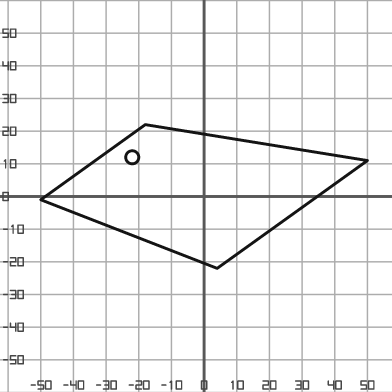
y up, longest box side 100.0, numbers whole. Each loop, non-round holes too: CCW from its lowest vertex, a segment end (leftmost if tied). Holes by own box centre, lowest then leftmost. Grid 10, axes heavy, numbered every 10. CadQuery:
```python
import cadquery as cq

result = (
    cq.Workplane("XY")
    .moveTo(4.0, -22.0)
    .lineTo(50.0, 11.0)
    .lineTo(-18.0, 22.0)
    .lineTo(-50.0, -1.0)
    .close()
    .moveTo(-22.0, 12.0)
    .circle(2.0)
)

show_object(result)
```